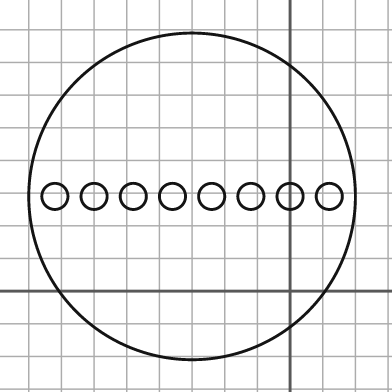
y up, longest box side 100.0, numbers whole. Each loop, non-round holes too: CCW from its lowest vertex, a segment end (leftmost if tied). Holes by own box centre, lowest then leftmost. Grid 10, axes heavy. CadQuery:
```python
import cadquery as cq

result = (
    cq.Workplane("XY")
    .moveTo(-30.0, 29.0)
    .circle(50.0)
    .moveTo(-72.0, 29.0)
    .circle(4.0)
    .moveTo(-60.0, 29.0)
    .circle(4.0)
    .moveTo(-48.0, 29.0)
    .circle(4.0)
    .moveTo(-36.0, 29.0)
    .circle(4.0)
    .moveTo(-24.0, 29.0)
    .circle(4.0)
    .moveTo(-12.0, 29.0)
    .circle(4.0)
    .moveTo(0.0, 29.0)
    .circle(4.0)
    .moveTo(12.0, 29.0)
    .circle(4.0)
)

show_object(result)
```